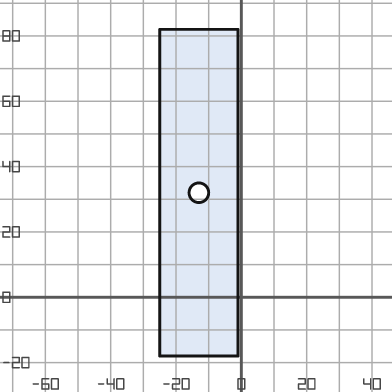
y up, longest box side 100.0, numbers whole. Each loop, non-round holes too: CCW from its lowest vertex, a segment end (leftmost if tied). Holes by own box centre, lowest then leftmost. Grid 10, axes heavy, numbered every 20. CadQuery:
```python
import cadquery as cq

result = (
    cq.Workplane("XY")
    .moveTo(-25.0, -18.0)
    .lineTo(-1.0, -18.0)
    .lineTo(-1.0, 82.0)
    .lineTo(-25.0, 82.0)
    .close()
    .moveTo(-13.0, 32.0)
    .circle(3.0)
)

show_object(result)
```